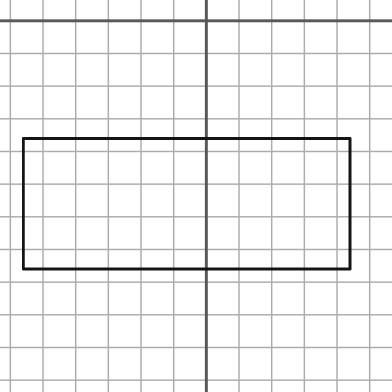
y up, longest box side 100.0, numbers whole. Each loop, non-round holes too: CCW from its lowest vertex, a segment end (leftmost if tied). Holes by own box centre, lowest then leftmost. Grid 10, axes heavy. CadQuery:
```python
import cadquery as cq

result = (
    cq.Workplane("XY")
    .moveTo(-56.0, -76.0)
    .lineTo(44.0, -76.0)
    .lineTo(44.0, -36.0)
    .lineTo(-56.0, -36.0)
    .close()
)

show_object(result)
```